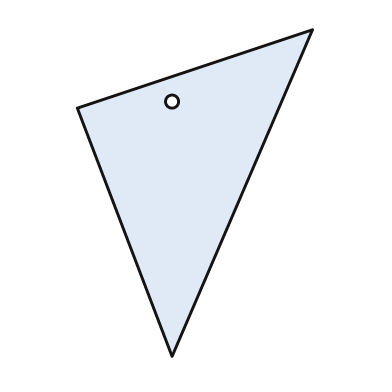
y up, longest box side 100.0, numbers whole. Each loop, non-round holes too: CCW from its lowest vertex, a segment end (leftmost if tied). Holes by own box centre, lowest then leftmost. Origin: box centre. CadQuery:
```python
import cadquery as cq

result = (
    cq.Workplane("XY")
    .moveTo(-7.0, -50.0)
    .lineTo(36.0, 50.0)
    .lineTo(-36.0, 26.0)
    .close()
    .moveTo(-7.0, 28.0)
    .circle(2.0)
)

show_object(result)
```